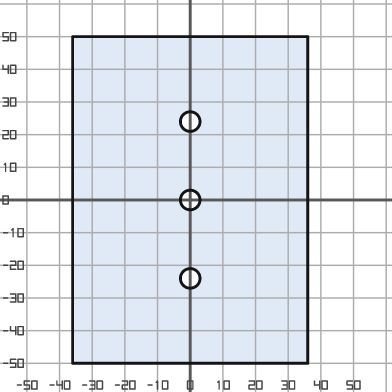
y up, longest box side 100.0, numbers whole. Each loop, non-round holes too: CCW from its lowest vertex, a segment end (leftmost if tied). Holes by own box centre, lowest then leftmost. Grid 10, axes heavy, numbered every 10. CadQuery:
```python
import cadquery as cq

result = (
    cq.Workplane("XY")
    .moveTo(-36.0, -50.0)
    .lineTo(36.0, -50.0)
    .lineTo(36.0, 50.0)
    .lineTo(-36.0, 50.0)
    .close()
    .moveTo(0.0, -24.0)
    .circle(3.0)
    .moveTo(0.0, 0.0)
    .circle(3.0)
    .moveTo(0.0, 24.0)
    .circle(3.0)
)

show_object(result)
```